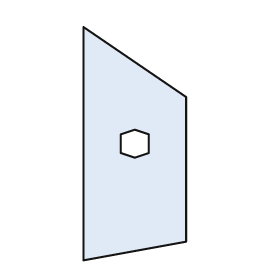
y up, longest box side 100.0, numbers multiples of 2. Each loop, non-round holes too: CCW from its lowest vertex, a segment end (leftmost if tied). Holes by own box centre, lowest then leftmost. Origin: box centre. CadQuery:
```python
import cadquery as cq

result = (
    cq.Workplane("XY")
    .moveTo(-22.0, -50.0)
    .lineTo(22.0, -42.0)
    .lineTo(22.0, 20.0)
    .lineTo(-22.0, 50.0)
    .close()
    .moveTo(0.0, -6.0)
    .lineTo(6.0, -4.0)
    .lineTo(6.0, 4.0)
    .lineTo(0.0, 6.0)
    .lineTo(-6.0, 4.0)
    .lineTo(-6.0, -4.0)
    .close()
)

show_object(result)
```